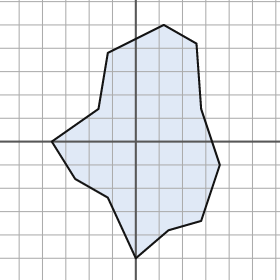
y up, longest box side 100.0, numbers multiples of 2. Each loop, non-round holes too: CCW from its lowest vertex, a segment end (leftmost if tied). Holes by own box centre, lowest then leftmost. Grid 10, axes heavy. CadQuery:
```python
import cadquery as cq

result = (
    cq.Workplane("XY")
    .moveTo(0.0, -50.0)
    .lineTo(14.0, -38.0)
    .lineTo(28.0, -34.0)
    .lineTo(36.0, -10.0)
    .lineTo(28.0, 14.0)
    .lineTo(26.0, 42.0)
    .lineTo(12.0, 50.0)
    .lineTo(-12.0, 38.0)
    .lineTo(-16.0, 14.0)
    .lineTo(-36.0, 0.0)
    .lineTo(-26.0, -16.0)
    .lineTo(-12.0, -24.0)
    .close()
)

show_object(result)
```